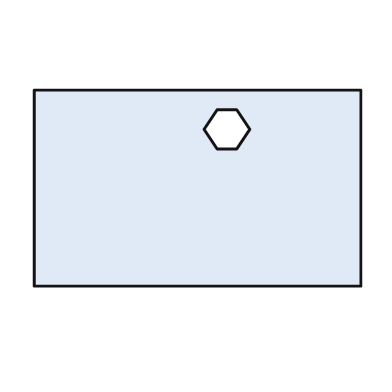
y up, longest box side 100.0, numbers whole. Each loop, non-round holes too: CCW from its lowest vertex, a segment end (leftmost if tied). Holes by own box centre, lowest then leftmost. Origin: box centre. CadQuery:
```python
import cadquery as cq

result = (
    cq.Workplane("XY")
    .moveTo(-50.0, -30.0)
    .lineTo(50.0, -30.0)
    .lineTo(50.0, 30.0)
    .lineTo(-50.0, 30.0)
    .close()
    .moveTo(6.0, 12.0)
    .lineTo(12.0, 12.0)
    .lineTo(16.0, 18.0)
    .lineTo(12.0, 24.0)
    .lineTo(6.0, 24.0)
    .lineTo(2.0, 18.0)
    .close()
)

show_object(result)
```